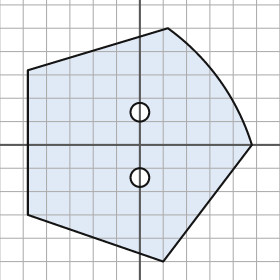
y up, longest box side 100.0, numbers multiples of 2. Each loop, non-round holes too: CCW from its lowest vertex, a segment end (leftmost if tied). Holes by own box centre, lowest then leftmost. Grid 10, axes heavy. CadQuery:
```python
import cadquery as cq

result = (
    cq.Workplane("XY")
    .moveTo(10.0, -50.0)
    .lineTo(48.0, 0.0)
    .threePointArc((34.0, 28.0), (12.0, 50.0))
    .lineTo(-48.0, 32.0)
    .lineTo(-48.0, -30.0)
    .close()
    .moveTo(0.0, -14.0)
    .circle(4.0)
    .moveTo(0.0, 14.0)
    .circle(4.0)
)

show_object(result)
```